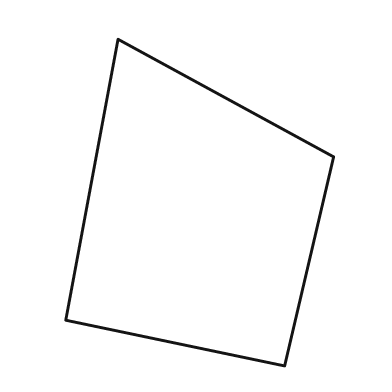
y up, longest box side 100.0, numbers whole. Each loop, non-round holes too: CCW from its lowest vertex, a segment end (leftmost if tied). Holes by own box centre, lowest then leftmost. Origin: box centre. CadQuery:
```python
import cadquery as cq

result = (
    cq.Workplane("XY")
    .moveTo(26.0, -50.0)
    .lineTo(41.0, 14.0)
    .lineTo(-25.0, 50.0)
    .lineTo(-41.0, -36.0)
    .close()
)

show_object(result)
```